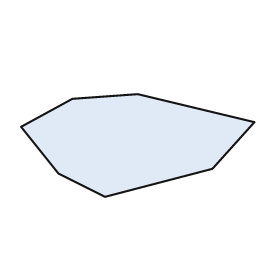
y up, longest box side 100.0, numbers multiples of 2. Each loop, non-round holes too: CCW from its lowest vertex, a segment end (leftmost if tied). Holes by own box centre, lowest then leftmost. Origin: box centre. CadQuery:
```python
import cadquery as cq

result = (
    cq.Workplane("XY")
    .moveTo(-14.0, -22.0)
    .lineTo(32.0, -10.0)
    .lineTo(50.0, 10.0)
    .lineTo(0.0, 22.0)
    .lineTo(-28.0, 20.0)
    .lineTo(-50.0, 8.0)
    .lineTo(-34.0, -12.0)
    .close()
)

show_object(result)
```